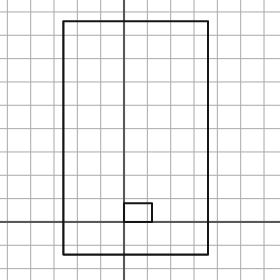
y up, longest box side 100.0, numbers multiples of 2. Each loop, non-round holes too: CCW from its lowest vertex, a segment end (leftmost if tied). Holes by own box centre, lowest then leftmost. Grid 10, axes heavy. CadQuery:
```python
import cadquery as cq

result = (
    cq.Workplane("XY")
    .moveTo(-26.0, -14.0)
    .lineTo(36.0, -14.0)
    .lineTo(36.0, 86.0)
    .lineTo(-26.0, 86.0)
    .close()
    .moveTo(0.0, 0.0)
    .lineTo(12.0, 0.0)
    .lineTo(12.0, 8.0)
    .lineTo(0.0, 8.0)
    .close()
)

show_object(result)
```